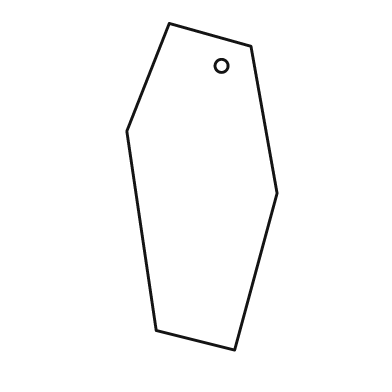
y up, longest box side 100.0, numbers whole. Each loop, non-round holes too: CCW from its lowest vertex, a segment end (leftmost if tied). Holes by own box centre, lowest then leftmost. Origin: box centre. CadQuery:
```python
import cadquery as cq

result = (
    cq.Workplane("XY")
    .moveTo(10.0, -50.0)
    .lineTo(23.0, -2.0)
    .lineTo(15.0, 43.0)
    .lineTo(-10.0, 50.0)
    .lineTo(-23.0, 17.0)
    .lineTo(-14.0, -44.0)
    .close()
    .moveTo(6.0, 37.0)
    .circle(2.0)
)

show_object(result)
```